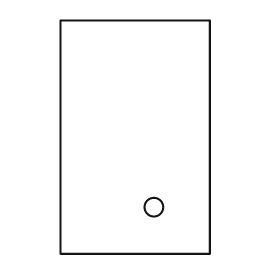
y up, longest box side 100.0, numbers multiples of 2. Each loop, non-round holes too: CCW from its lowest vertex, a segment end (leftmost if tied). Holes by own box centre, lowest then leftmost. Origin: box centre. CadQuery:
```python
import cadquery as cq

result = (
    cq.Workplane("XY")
    .moveTo(-32.0, -50.0)
    .lineTo(32.0, -50.0)
    .lineTo(32.0, 50.0)
    .lineTo(-32.0, 50.0)
    .close()
    .moveTo(8.0, -30.0)
    .circle(4.0)
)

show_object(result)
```